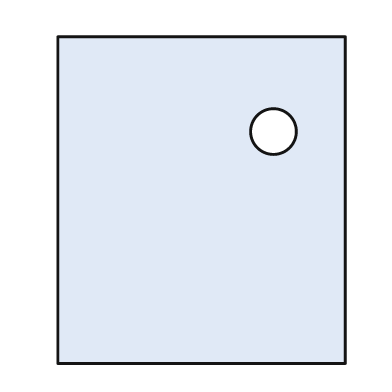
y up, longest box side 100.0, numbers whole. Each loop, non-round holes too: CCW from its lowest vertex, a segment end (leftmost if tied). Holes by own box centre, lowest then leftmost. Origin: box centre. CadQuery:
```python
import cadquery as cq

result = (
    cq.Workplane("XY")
    .moveTo(-44.0, -50.0)
    .lineTo(44.0, -50.0)
    .lineTo(44.0, 50.0)
    .lineTo(-44.0, 50.0)
    .close()
    .moveTo(22.0, 21.0)
    .circle(7.0)
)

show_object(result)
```